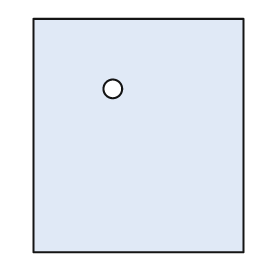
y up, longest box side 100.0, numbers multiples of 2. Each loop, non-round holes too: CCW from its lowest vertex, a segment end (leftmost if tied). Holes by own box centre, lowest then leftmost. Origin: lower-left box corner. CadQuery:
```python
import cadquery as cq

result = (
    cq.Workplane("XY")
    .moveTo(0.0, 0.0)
    .lineTo(90.0, 0.0)
    .lineTo(90.0, 100.0)
    .lineTo(0.0, 100.0)
    .close()
    .moveTo(34.0, 70.0)
    .circle(4.0)
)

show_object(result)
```